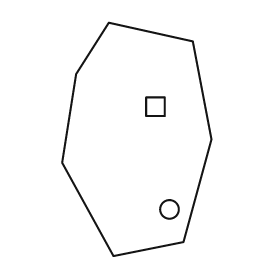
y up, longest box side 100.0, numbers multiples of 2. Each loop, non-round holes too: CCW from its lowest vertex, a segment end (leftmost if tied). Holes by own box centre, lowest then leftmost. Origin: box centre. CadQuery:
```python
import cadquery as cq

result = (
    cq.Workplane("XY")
    .moveTo(-10.0, -50.0)
    .lineTo(20.0, -44.0)
    .lineTo(32.0, 0.0)
    .lineTo(24.0, 42.0)
    .lineTo(-12.0, 50.0)
    .lineTo(-26.0, 28.0)
    .lineTo(-32.0, -10.0)
    .close()
    .moveTo(14.0, -30.0)
    .circle(4.0)
    .moveTo(4.0, 10.0)
    .lineTo(12.0, 10.0)
    .lineTo(12.0, 18.0)
    .lineTo(4.0, 18.0)
    .close()
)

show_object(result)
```